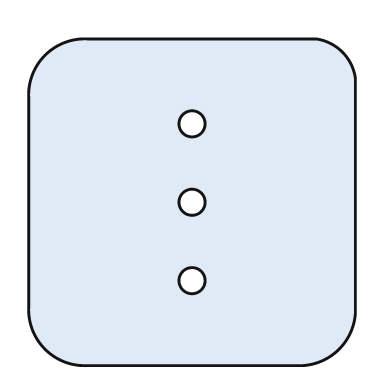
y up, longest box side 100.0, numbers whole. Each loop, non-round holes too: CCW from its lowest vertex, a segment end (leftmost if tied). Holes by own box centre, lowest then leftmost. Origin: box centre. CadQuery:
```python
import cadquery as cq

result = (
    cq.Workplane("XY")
    .moveTo(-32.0, -50.0)
    .lineTo(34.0, -50.0)
    .threePointArc((45.0, -45.0), (50.0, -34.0))
    .lineTo(50.0, 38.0)
    .threePointArc((46.0, 46.0), (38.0, 50.0))
    .lineTo(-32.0, 50.0)
    .threePointArc((-45.0, 45.0), (-50.0, 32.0))
    .lineTo(-50.0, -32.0)
    .threePointArc((-45.0, -45.0), (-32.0, -50.0))
    .close()
    .moveTo(0.0, -24.0)
    .circle(4.0)
    .moveTo(0.0, 0.0)
    .circle(4.0)
    .moveTo(0.0, 24.0)
    .circle(4.0)
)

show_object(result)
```